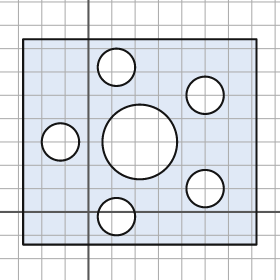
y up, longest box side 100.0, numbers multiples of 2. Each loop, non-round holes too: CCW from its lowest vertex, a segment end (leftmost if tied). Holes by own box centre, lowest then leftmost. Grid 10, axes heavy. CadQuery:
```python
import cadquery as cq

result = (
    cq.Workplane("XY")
    .moveTo(-28.0, -14.0)
    .lineTo(72.0, -14.0)
    .lineTo(72.0, 74.0)
    .lineTo(-28.0, 74.0)
    .close()
    .moveTo(12.0, -2.0)
    .circle(8.0)
    .moveTo(50.0, 10.0)
    .circle(8.0)
    .moveTo(-12.0, 30.0)
    .circle(8.0)
    .moveTo(22.0, 30.0)
    .circle(16.0)
    .moveTo(50.0, 50.0)
    .circle(8.0)
    .moveTo(12.0, 62.0)
    .circle(8.0)
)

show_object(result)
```